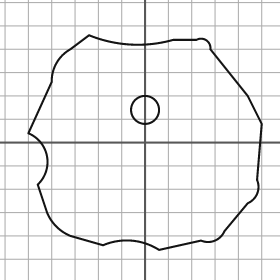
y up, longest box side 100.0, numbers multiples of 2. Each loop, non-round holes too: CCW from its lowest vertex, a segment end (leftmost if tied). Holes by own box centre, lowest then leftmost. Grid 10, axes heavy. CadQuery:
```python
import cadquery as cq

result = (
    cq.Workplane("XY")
    .moveTo(6.0, -46.0)
    .lineTo(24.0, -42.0)
    .threePointArc((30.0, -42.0), (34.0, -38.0))
    .lineTo(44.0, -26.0)
    .threePointArc((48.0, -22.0), (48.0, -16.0))
    .lineTo(50.0, 8.0)
    .lineTo(44.0, 20.0)
    .lineTo(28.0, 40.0)
    .threePointArc((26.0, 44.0), (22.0, 44.0))
    .lineTo(12.0, 44.0)
    .threePointArc((-6.0, 42.0), (-24.0, 46.0))
    .lineTo(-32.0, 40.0)
    .threePointArc((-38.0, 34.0), (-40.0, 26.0))
    .lineTo(-50.0, 4.0)
    .threePointArc((-42.0, -6.0), (-46.0, -18.0))
    .lineTo(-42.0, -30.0)
    .threePointArc((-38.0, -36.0), (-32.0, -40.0))
    .lineTo(-18.0, -44.0)
    .threePointArc((-6.0, -42.0), (6.0, -46.0))
    .close()
    .moveTo(0.0, 14.0)
    .circle(6.0)
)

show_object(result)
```